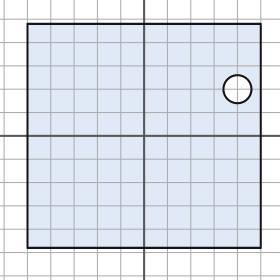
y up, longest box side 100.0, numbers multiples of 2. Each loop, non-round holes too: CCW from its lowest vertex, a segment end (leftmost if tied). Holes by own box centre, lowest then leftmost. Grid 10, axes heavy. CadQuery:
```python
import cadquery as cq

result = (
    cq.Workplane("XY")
    .moveTo(-50.0, -48.0)
    .lineTo(50.0, -48.0)
    .lineTo(50.0, 48.0)
    .lineTo(-50.0, 48.0)
    .close()
    .moveTo(40.0, 20.0)
    .circle(6.0)
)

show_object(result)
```